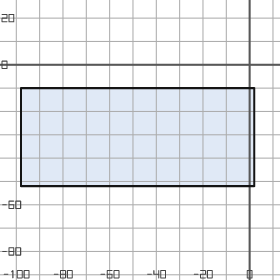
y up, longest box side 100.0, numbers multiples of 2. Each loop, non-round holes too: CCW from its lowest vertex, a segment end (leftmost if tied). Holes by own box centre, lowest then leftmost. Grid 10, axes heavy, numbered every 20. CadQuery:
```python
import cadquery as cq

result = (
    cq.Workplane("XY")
    .moveTo(-98.0, -52.0)
    .lineTo(2.0, -52.0)
    .lineTo(2.0, -10.0)
    .lineTo(-98.0, -10.0)
    .close()
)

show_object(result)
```